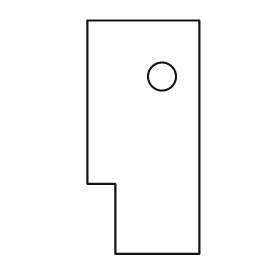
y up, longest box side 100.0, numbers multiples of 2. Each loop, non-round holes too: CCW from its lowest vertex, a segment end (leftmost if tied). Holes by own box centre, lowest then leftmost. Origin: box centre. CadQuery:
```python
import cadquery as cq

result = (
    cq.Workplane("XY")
    .moveTo(-12.0, -50.0)
    .lineTo(24.0, -50.0)
    .lineTo(24.0, 50.0)
    .lineTo(-24.0, 50.0)
    .lineTo(-24.0, -20.0)
    .lineTo(-12.0, -20.0)
    .close()
    .moveTo(8.0, 26.0)
    .circle(6.0)
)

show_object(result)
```